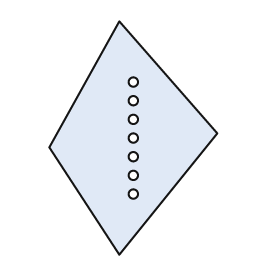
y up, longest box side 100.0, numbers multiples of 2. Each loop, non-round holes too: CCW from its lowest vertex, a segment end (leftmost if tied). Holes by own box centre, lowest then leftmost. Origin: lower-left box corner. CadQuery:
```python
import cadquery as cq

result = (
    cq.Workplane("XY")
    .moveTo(30.0, 0.0)
    .lineTo(72.0, 52.0)
    .lineTo(30.0, 100.0)
    .lineTo(0.0, 46.0)
    .close()
    .moveTo(36.0, 26.0)
    .circle(2.0)
    .moveTo(36.0, 34.0)
    .circle(2.0)
    .moveTo(36.0, 42.0)
    .circle(2.0)
    .moveTo(36.0, 50.0)
    .circle(2.0)
    .moveTo(36.0, 58.0)
    .circle(2.0)
    .moveTo(36.0, 66.0)
    .circle(2.0)
    .moveTo(36.0, 74.0)
    .circle(2.0)
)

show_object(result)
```